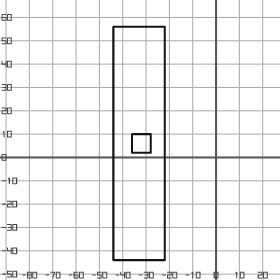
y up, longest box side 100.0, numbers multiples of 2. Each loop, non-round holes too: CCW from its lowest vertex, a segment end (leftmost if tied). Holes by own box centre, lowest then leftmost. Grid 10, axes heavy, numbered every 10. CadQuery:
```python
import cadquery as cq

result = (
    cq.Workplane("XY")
    .moveTo(-44.0, -44.0)
    .lineTo(-22.0, -44.0)
    .lineTo(-22.0, 56.0)
    .lineTo(-44.0, 56.0)
    .close()
    .moveTo(-36.0, 2.0)
    .lineTo(-28.0, 2.0)
    .lineTo(-28.0, 10.0)
    .lineTo(-36.0, 10.0)
    .close()
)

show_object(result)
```